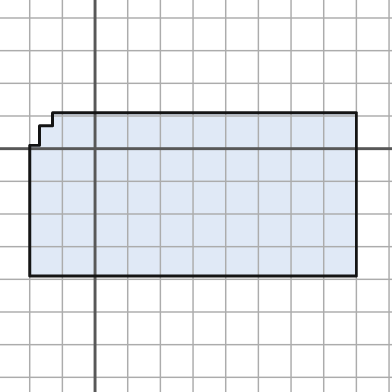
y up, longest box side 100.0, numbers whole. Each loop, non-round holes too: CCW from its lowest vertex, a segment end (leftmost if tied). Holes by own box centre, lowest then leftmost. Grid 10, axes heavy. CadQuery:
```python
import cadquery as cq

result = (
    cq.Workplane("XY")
    .moveTo(-20.0, -39.0)
    .lineTo(80.0, -39.0)
    .lineTo(80.0, 11.0)
    .lineTo(-13.0, 11.0)
    .lineTo(-13.0, 7.0)
    .lineTo(-17.0, 7.0)
    .lineTo(-17.0, 1.0)
    .lineTo(-20.0, 1.0)
    .close()
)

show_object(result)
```